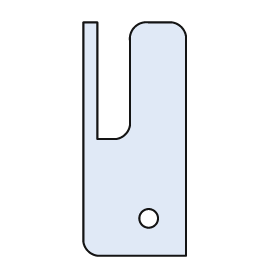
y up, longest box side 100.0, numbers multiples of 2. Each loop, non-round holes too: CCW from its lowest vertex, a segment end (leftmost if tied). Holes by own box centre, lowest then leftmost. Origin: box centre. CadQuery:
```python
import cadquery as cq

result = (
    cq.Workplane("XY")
    .moveTo(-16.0, -50.0)
    .lineTo(22.0, -50.0)
    .lineTo(22.0, 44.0)
    .threePointArc((20.0, 48.0), (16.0, 50.0))
    .lineTo(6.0, 50.0)
    .threePointArc((0.0, 48.0), (-2.0, 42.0))
    .lineTo(-2.0, 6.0)
    .threePointArc((-4.0, 2.0), (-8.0, 0.0))
    .lineTo(-16.0, 0.0)
    .lineTo(-16.0, 50.0)
    .lineTo(-22.0, 50.0)
    .lineTo(-22.0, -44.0)
    .threePointArc((-20.0, -48.0), (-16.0, -50.0))
    .close()
    .moveTo(6.0, -34.0)
    .circle(4.0)
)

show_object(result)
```